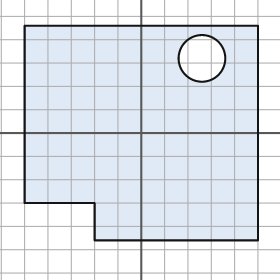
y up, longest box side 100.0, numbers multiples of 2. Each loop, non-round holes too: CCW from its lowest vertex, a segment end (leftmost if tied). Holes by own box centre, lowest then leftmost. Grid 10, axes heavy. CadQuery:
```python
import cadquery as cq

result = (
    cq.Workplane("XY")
    .moveTo(-20.0, -46.0)
    .lineTo(50.0, -46.0)
    .lineTo(50.0, 46.0)
    .lineTo(-50.0, 46.0)
    .lineTo(-50.0, -30.0)
    .lineTo(-20.0, -30.0)
    .close()
    .moveTo(26.0, 32.0)
    .circle(10.0)
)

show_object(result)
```